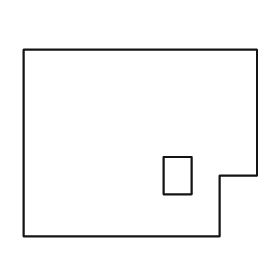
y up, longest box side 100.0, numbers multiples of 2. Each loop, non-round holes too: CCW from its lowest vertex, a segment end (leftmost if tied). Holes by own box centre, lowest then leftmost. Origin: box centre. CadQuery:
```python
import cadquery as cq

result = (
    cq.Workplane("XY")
    .moveTo(-50.0, -40.0)
    .lineTo(34.0, -40.0)
    .lineTo(34.0, -14.0)
    .lineTo(50.0, -14.0)
    .lineTo(50.0, 40.0)
    .lineTo(-50.0, 40.0)
    .close()
    .moveTo(10.0, -22.0)
    .lineTo(22.0, -22.0)
    .lineTo(22.0, -6.0)
    .lineTo(10.0, -6.0)
    .close()
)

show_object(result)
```